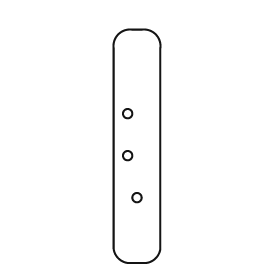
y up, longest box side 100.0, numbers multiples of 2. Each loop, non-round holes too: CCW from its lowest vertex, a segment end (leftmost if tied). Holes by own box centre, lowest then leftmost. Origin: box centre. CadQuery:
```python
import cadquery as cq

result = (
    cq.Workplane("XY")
    .moveTo(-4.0, -50.0)
    .lineTo(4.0, -50.0)
    .threePointArc((8.0, -48.0), (10.0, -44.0))
    .lineTo(10.0, 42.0)
    .threePointArc((8.0, 48.0), (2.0, 50.0))
    .lineTo(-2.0, 50.0)
    .threePointArc((-8.0, 48.0), (-10.0, 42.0))
    .lineTo(-10.0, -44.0)
    .threePointArc((-8.0, -48.0), (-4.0, -50.0))
    .close()
    .moveTo(0.0, -22.0)
    .circle(2.0)
    .moveTo(-4.0, -4.0)
    .circle(2.0)
    .moveTo(-4.0, 14.0)
    .circle(2.0)
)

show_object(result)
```